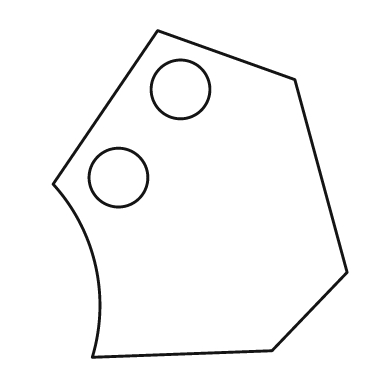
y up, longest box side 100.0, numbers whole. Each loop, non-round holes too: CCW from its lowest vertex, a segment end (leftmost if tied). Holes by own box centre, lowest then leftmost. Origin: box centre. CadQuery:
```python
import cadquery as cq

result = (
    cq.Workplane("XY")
    .moveTo(-33.0, -50.0)
    .lineTo(22.0, -48.0)
    .lineTo(45.0, -24.0)
    .lineTo(29.0, 35.0)
    .lineTo(-13.0, 50.0)
    .lineTo(-45.0, 3.0)
    .threePointArc((-32.0, -22.0), (-33.0, -50.0))
    .close()
    .moveTo(-25.0, 5.0)
    .circle(9.0)
    .moveTo(-6.0, 32.0)
    .circle(9.0)
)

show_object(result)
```